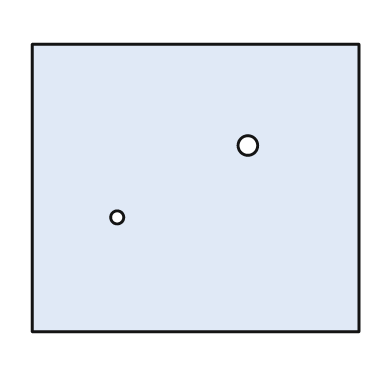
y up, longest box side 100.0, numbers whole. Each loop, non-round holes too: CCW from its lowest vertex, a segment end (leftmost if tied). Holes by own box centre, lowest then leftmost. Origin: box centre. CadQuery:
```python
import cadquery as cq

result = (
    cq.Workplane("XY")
    .moveTo(-50.0, -44.0)
    .lineTo(50.0, -44.0)
    .lineTo(50.0, 44.0)
    .lineTo(-50.0, 44.0)
    .close()
    .moveTo(-24.0, -9.0)
    .circle(2.0)
    .moveTo(16.0, 13.0)
    .circle(3.0)
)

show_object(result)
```